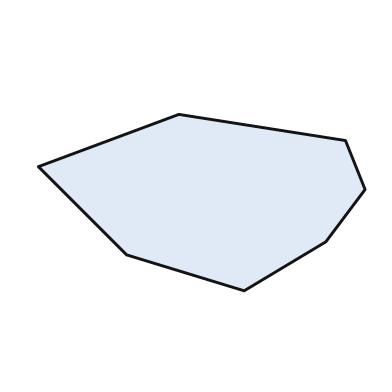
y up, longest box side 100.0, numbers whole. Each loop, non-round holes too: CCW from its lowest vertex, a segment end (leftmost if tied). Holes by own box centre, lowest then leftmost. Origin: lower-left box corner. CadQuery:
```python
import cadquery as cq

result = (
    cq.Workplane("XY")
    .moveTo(63.0, 0.0)
    .lineTo(88.0, 15.0)
    .lineTo(100.0, 31.0)
    .lineTo(94.0, 46.0)
    .lineTo(43.0, 54.0)
    .lineTo(0.0, 38.0)
    .lineTo(27.0, 11.0)
    .close()
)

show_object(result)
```